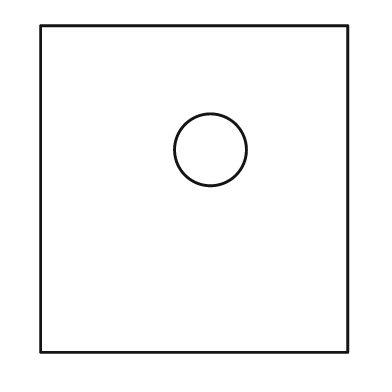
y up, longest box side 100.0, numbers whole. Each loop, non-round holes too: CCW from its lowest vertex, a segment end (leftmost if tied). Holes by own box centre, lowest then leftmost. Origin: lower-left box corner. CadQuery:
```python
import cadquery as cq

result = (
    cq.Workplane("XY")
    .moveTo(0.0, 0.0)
    .lineTo(94.0, 0.0)
    .lineTo(94.0, 100.0)
    .lineTo(0.0, 100.0)
    .close()
    .moveTo(52.0, 62.0)
    .circle(11.0)
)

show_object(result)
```